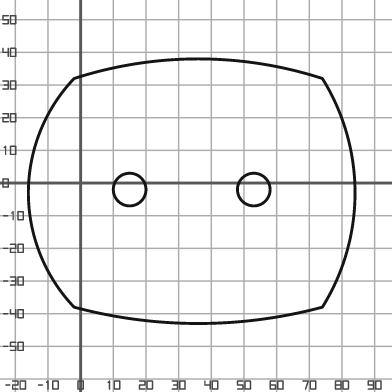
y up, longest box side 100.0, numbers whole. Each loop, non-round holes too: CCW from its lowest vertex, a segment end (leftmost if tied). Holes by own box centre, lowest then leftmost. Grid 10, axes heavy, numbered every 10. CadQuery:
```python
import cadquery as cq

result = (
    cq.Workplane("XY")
    .moveTo(-2.0, -38.0)
    .threePointArc((36.0, -43.0), (74.0, -38.0))
    .threePointArc((84.0, -3.0), (74.0, 32.0))
    .threePointArc((36.0, 38.0), (-2.0, 32.0))
    .threePointArc((-16.0, -3.0), (-2.0, -38.0))
    .close()
    .moveTo(15.0, -2.0)
    .circle(5.0)
    .moveTo(53.0, -2.0)
    .circle(5.0)
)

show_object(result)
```